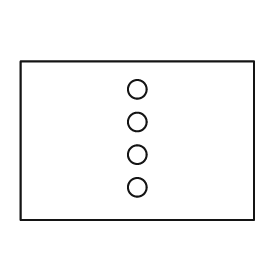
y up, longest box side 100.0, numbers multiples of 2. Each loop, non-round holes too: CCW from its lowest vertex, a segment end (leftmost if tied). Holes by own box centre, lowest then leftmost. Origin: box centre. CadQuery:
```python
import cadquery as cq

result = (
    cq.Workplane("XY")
    .moveTo(-50.0, -34.0)
    .lineTo(50.0, -34.0)
    .lineTo(50.0, 34.0)
    .lineTo(-50.0, 34.0)
    .close()
    .moveTo(0.0, -20.0)
    .circle(4.0)
    .moveTo(0.0, -6.0)
    .circle(4.0)
    .moveTo(0.0, 8.0)
    .circle(4.0)
    .moveTo(0.0, 22.0)
    .circle(4.0)
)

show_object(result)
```